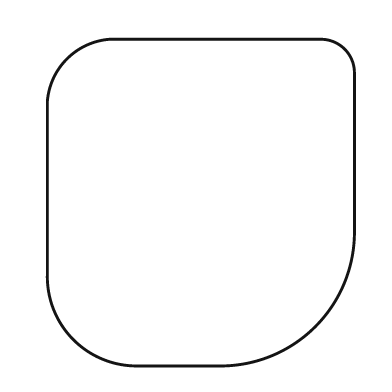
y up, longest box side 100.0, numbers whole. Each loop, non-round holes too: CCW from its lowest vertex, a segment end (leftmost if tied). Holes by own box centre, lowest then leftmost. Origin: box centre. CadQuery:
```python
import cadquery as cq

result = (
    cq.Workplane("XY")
    .moveTo(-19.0, -50.0)
    .lineTo(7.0, -50.0)
    .threePointArc((35.0, -38.0), (47.0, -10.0))
    .lineTo(47.0, 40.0)
    .threePointArc((44.0, 47.0), (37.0, 50.0))
    .lineTo(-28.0, 50.0)
    .threePointArc((-41.0, 44.0), (-47.0, 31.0))
    .lineTo(-47.0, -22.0)
    .threePointArc((-39.0, -42.0), (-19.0, -50.0))
    .close()
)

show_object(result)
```